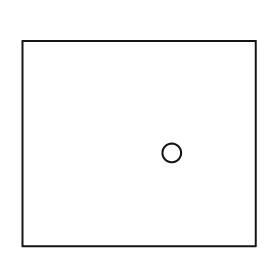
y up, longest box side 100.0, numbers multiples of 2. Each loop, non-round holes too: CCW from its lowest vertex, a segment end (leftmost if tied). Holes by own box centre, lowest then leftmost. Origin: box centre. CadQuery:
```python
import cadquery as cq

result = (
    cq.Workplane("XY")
    .moveTo(-50.0, -44.0)
    .lineTo(50.0, -44.0)
    .lineTo(50.0, 44.0)
    .lineTo(-50.0, 44.0)
    .close()
    .moveTo(14.0, -4.0)
    .circle(4.0)
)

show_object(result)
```